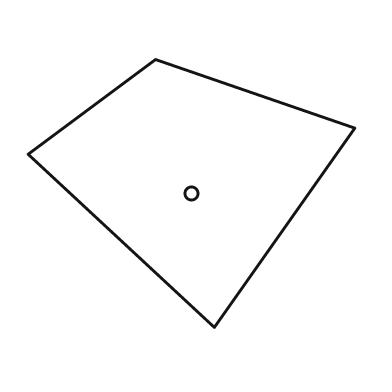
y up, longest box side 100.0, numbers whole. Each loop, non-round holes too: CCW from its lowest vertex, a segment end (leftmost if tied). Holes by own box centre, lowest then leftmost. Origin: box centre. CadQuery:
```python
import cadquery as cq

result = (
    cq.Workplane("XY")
    .moveTo(7.0, -41.0)
    .lineTo(50.0, 20.0)
    .lineTo(-11.0, 41.0)
    .lineTo(-50.0, 12.0)
    .close()
    .moveTo(0.0, 0.0)
    .circle(2.0)
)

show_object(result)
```